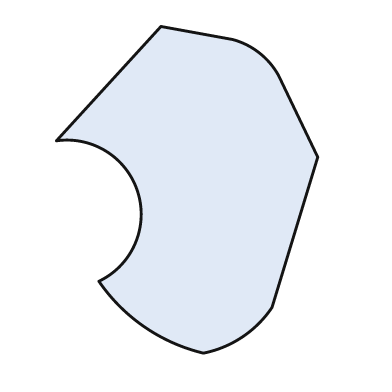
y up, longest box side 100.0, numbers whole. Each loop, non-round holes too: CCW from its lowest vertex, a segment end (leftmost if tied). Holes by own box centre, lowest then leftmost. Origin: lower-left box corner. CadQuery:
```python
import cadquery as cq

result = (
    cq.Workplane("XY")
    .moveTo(45.0, 0.0)
    .threePointArc((57.0, 5.0), (66.0, 14.0))
    .lineTo(80.0, 60.0)
    .lineTo(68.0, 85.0)
    .threePointArc((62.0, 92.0), (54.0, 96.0))
    .lineTo(32.0, 100.0)
    .lineTo(0.0, 65.0)
    .threePointArc((25.0, 49.0), (13.0, 22.0))
    .threePointArc((27.0, 8.0), (45.0, 0.0))
    .close()
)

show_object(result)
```